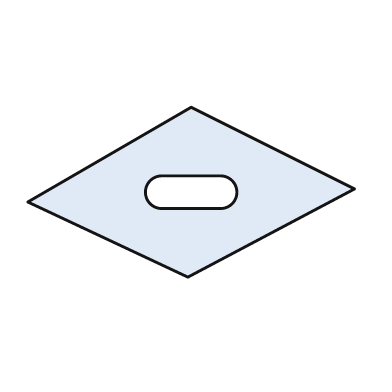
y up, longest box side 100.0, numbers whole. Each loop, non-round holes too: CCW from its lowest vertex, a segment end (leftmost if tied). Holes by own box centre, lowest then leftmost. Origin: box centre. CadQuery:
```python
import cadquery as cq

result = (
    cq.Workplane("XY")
    .moveTo(-1.0, -26.0)
    .lineTo(50.0, 1.0)
    .lineTo(0.0, 26.0)
    .lineTo(-50.0, -3.0)
    .close()
    .moveTo(-9.0, -5.0)
    .lineTo(9.0, -5.0)
    .threePointArc((14.0, 0.0), (9.0, 5.0))
    .lineTo(-9.0, 5.0)
    .threePointArc((-14.0, 0.0), (-9.0, -5.0))
    .close()
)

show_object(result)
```